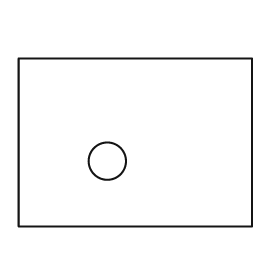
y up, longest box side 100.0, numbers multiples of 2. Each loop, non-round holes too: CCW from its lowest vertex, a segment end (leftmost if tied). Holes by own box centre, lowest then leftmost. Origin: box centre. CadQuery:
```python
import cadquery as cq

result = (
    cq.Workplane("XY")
    .moveTo(-50.0, -36.0)
    .lineTo(50.0, -36.0)
    .lineTo(50.0, 36.0)
    .lineTo(-50.0, 36.0)
    .close()
    .moveTo(-12.0, -8.0)
    .circle(8.0)
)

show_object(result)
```